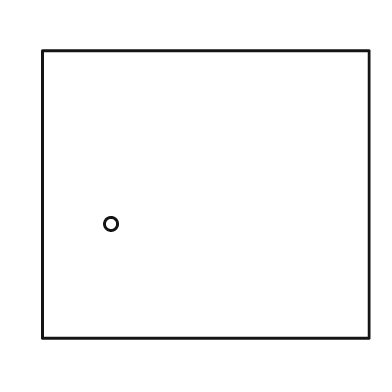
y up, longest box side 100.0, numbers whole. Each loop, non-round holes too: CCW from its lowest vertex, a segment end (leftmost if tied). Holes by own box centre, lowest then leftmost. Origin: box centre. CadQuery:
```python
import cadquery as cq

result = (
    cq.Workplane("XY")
    .moveTo(-50.0, -44.0)
    .lineTo(50.0, -44.0)
    .lineTo(50.0, 44.0)
    .lineTo(-50.0, 44.0)
    .close()
    .moveTo(-29.0, -9.0)
    .circle(2.0)
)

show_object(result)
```